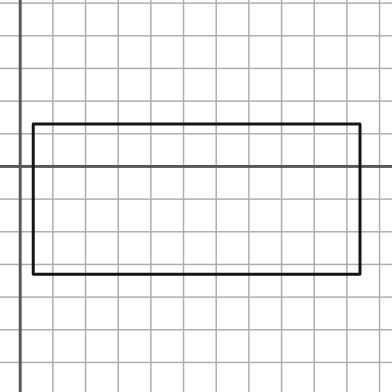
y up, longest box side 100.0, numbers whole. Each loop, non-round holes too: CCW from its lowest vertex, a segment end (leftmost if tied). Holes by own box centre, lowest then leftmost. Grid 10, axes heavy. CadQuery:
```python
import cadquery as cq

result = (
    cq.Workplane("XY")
    .moveTo(4.0, -33.0)
    .lineTo(104.0, -33.0)
    .lineTo(104.0, 13.0)
    .lineTo(4.0, 13.0)
    .close()
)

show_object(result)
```